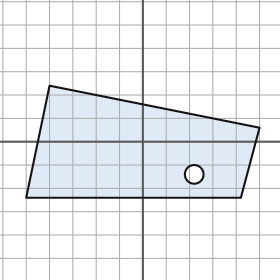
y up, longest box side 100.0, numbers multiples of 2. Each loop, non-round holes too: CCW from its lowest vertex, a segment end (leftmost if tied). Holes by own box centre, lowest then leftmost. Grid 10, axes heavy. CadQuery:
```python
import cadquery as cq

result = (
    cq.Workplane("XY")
    .moveTo(-50.0, -24.0)
    .lineTo(42.0, -24.0)
    .lineTo(50.0, 6.0)
    .lineTo(-40.0, 24.0)
    .close()
    .moveTo(22.0, -14.0)
    .circle(4.0)
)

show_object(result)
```